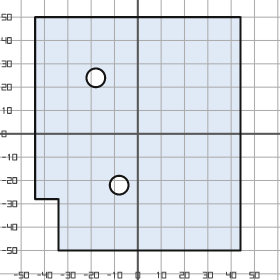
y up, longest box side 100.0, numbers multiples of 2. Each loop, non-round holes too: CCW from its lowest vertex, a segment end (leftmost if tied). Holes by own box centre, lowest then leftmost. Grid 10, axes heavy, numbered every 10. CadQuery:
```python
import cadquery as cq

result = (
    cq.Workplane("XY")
    .moveTo(-34.0, -50.0)
    .lineTo(44.0, -50.0)
    .lineTo(44.0, 50.0)
    .lineTo(-44.0, 50.0)
    .lineTo(-44.0, -28.0)
    .lineTo(-34.0, -28.0)
    .close()
    .moveTo(-8.0, -22.0)
    .circle(4.0)
    .moveTo(-18.0, 24.0)
    .circle(4.0)
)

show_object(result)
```